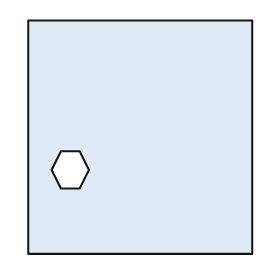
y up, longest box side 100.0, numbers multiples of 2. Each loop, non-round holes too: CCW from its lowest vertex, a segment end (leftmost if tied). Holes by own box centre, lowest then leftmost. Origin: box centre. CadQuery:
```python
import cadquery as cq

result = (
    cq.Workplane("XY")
    .moveTo(-48.0, -50.0)
    .lineTo(48.0, -50.0)
    .lineTo(48.0, 50.0)
    .lineTo(-48.0, 50.0)
    .close()
    .moveTo(-34.0, -22.0)
    .lineTo(-26.0, -22.0)
    .lineTo(-22.0, -14.0)
    .lineTo(-26.0, -6.0)
    .lineTo(-34.0, -6.0)
    .lineTo(-38.0, -14.0)
    .close()
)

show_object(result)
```